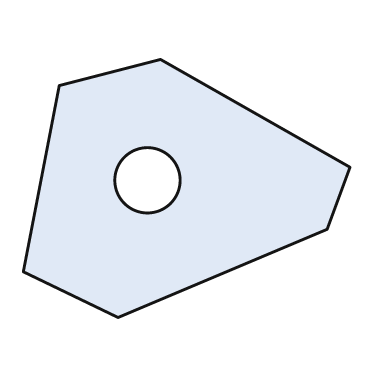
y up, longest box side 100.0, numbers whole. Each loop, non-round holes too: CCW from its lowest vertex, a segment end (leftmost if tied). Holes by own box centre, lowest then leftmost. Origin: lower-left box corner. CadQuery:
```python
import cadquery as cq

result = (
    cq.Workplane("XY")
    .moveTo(29.0, 0.0)
    .lineTo(93.0, 27.0)
    .lineTo(100.0, 46.0)
    .lineTo(42.0, 79.0)
    .lineTo(11.0, 71.0)
    .lineTo(0.0, 14.0)
    .close()
    .moveTo(38.0, 42.0)
    .circle(10.0)
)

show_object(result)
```